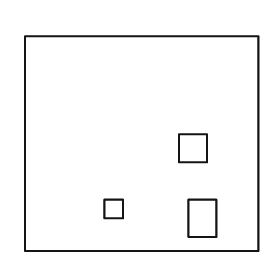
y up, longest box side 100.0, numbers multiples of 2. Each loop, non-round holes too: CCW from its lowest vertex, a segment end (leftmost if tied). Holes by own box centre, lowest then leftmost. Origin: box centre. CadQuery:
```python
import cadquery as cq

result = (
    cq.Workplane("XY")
    .moveTo(-50.0, -46.0)
    .lineTo(50.0, -46.0)
    .lineTo(50.0, 46.0)
    .lineTo(-50.0, 46.0)
    .close()
    .moveTo(20.0, -40.0)
    .lineTo(32.0, -40.0)
    .lineTo(32.0, -24.0)
    .lineTo(20.0, -24.0)
    .close()
    .moveTo(-16.0, -32.0)
    .lineTo(-8.0, -32.0)
    .lineTo(-8.0, -24.0)
    .lineTo(-16.0, -24.0)
    .close()
    .moveTo(16.0, -8.0)
    .lineTo(28.0, -8.0)
    .lineTo(28.0, 4.0)
    .lineTo(16.0, 4.0)
    .close()
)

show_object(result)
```